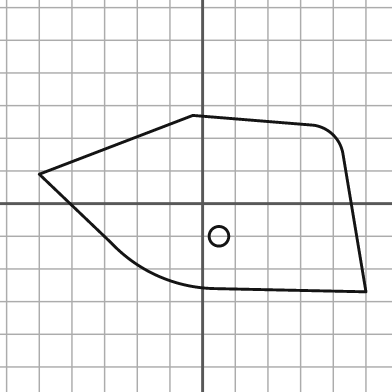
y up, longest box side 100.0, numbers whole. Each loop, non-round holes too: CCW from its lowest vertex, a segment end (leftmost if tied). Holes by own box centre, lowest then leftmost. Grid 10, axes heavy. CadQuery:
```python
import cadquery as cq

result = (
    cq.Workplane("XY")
    .moveTo(50.0, -27.0)
    .lineTo(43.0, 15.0)
    .threePointArc((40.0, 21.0), (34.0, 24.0))
    .lineTo(-3.0, 27.0)
    .lineTo(-50.0, 9.0)
    .lineTo(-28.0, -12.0)
    .threePointArc((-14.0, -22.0), (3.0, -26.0))
    .close()
    .moveTo(5.0, -10.0)
    .circle(3.0)
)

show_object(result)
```